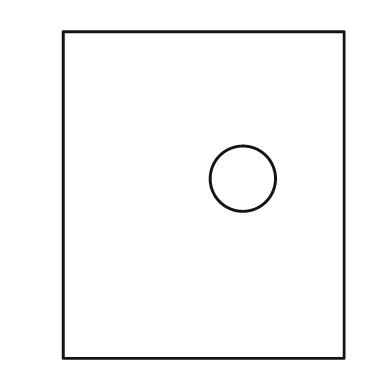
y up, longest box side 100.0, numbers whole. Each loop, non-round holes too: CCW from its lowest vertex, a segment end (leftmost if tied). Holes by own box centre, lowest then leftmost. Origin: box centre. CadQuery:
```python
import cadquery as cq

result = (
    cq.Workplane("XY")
    .moveTo(-43.0, -50.0)
    .lineTo(43.0, -50.0)
    .lineTo(43.0, 50.0)
    .lineTo(-43.0, 50.0)
    .close()
    .moveTo(12.0, 5.0)
    .circle(10.0)
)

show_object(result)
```